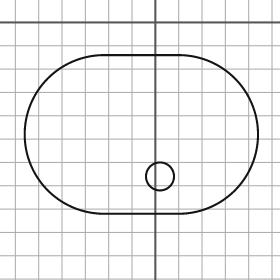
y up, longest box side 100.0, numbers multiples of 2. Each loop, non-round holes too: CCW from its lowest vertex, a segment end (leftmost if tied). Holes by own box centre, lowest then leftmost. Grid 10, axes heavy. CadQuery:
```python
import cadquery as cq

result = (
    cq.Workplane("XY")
    .moveTo(-22.0, -82.0)
    .lineTo(10.0, -82.0)
    .threePointArc((44.0, -48.0), (10.0, -14.0))
    .lineTo(-22.0, -14.0)
    .threePointArc((-56.0, -48.0), (-22.0, -82.0))
    .close()
    .moveTo(2.0, -66.0)
    .circle(6.0)
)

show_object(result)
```